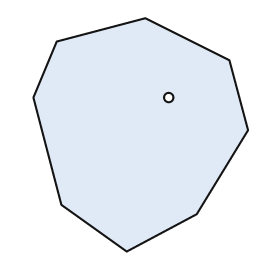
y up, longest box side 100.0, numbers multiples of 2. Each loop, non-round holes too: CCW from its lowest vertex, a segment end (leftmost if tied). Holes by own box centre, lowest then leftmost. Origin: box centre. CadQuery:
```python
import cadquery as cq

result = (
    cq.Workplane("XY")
    .moveTo(-6.0, -50.0)
    .lineTo(24.0, -34.0)
    .lineTo(46.0, 2.0)
    .lineTo(38.0, 32.0)
    .lineTo(2.0, 50.0)
    .lineTo(-36.0, 40.0)
    .lineTo(-46.0, 16.0)
    .lineTo(-34.0, -30.0)
    .close()
    .moveTo(12.0, 16.0)
    .circle(2.0)
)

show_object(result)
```